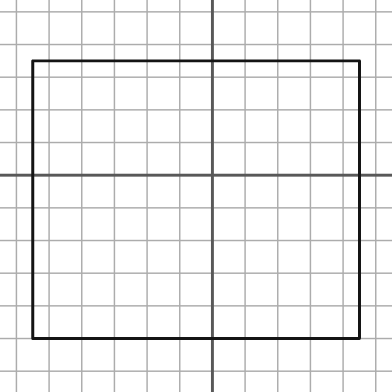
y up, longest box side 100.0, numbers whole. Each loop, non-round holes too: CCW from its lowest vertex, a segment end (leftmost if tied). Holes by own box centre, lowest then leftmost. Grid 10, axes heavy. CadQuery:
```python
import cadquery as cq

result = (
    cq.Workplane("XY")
    .moveTo(-55.0, -50.0)
    .lineTo(45.0, -50.0)
    .lineTo(45.0, 35.0)
    .lineTo(-55.0, 35.0)
    .close()
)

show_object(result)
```